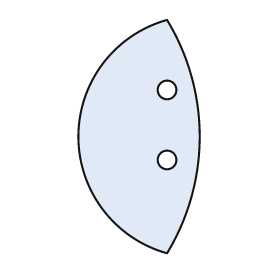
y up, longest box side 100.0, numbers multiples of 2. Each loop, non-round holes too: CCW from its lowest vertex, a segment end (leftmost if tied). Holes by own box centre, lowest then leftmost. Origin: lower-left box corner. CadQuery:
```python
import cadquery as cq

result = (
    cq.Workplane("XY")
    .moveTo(38.0, 0.0)
    .threePointArc((52.0, 50.0), (38.0, 100.0))
    .threePointArc((0.0, 50.0), (38.0, 0.0))
    .close()
    .moveTo(38.0, 40.0)
    .circle(4.0)
    .moveTo(38.0, 70.0)
    .circle(4.0)
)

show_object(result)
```